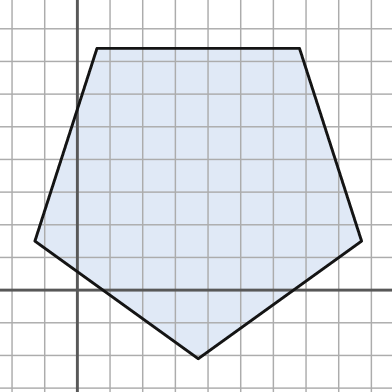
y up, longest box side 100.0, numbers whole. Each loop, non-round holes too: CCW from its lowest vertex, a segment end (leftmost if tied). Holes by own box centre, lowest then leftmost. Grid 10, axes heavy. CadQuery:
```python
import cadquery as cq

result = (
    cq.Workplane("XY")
    .moveTo(37.0, -21.0)
    .lineTo(87.0, 15.0)
    .lineTo(68.0, 74.0)
    .lineTo(6.0, 74.0)
    .lineTo(-13.0, 15.0)
    .close()
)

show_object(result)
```